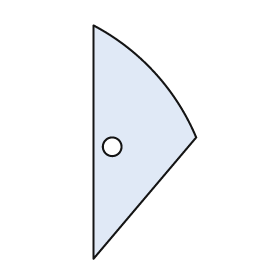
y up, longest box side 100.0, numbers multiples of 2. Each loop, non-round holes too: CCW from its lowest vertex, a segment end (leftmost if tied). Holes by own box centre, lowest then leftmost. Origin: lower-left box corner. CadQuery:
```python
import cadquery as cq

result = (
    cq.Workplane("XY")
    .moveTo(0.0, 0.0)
    .lineTo(44.0, 52.0)
    .threePointArc((26.0, 80.0), (0.0, 100.0))
    .close()
    .moveTo(8.0, 48.0)
    .circle(4.0)
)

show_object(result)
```